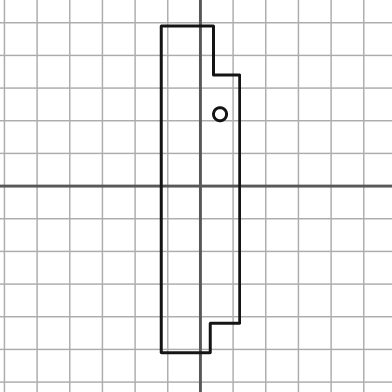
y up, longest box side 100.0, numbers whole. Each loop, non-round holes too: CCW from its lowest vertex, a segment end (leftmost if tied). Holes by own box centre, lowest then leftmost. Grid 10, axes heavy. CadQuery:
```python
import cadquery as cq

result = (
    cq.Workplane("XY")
    .moveTo(-12.0, -51.0)
    .lineTo(3.0, -51.0)
    .lineTo(3.0, -42.0)
    .lineTo(12.0, -42.0)
    .lineTo(12.0, 34.0)
    .lineTo(4.0, 34.0)
    .lineTo(4.0, 49.0)
    .lineTo(-12.0, 49.0)
    .close()
    .moveTo(6.0, 22.0)
    .circle(2.0)
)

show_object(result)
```